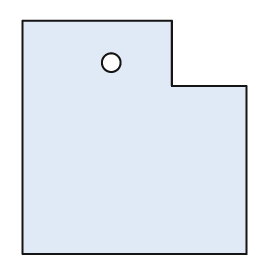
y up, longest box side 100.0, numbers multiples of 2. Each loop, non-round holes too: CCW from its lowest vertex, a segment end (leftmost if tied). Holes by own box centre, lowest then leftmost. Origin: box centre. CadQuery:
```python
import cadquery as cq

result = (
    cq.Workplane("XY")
    .moveTo(-48.0, -50.0)
    .lineTo(48.0, -50.0)
    .lineTo(48.0, 22.0)
    .lineTo(16.0, 22.0)
    .lineTo(16.0, 50.0)
    .lineTo(-48.0, 50.0)
    .close()
    .moveTo(-10.0, 32.0)
    .circle(4.0)
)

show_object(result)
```